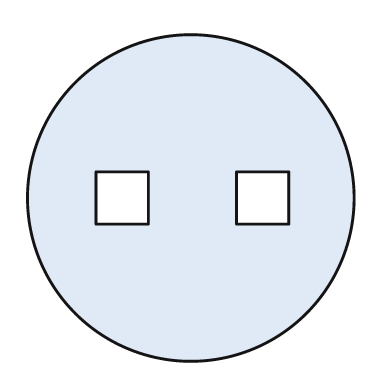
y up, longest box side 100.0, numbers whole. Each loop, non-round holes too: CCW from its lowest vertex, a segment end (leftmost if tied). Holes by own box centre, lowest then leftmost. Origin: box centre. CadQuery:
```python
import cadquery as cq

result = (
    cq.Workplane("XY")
    .moveTo(0.0, 0.0)
    .circle(50.0)
    .moveTo(-29.0, -8.0)
    .lineTo(-13.0, -8.0)
    .lineTo(-13.0, 8.0)
    .lineTo(-29.0, 8.0)
    .close()
    .moveTo(14.0, -8.0)
    .lineTo(30.0, -8.0)
    .lineTo(30.0, 8.0)
    .lineTo(14.0, 8.0)
    .close()
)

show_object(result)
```